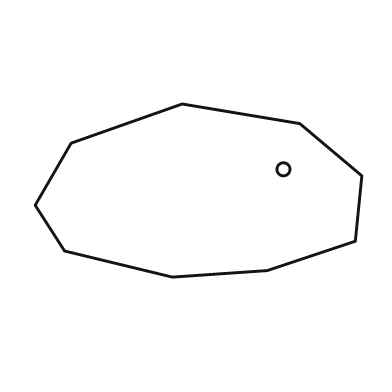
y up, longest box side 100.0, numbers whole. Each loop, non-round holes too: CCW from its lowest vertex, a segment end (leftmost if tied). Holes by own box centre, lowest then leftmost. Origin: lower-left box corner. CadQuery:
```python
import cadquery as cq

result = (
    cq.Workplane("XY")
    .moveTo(42.0, 0.0)
    .lineTo(71.0, 2.0)
    .lineTo(98.0, 11.0)
    .lineTo(100.0, 31.0)
    .lineTo(81.0, 47.0)
    .lineTo(45.0, 53.0)
    .lineTo(11.0, 41.0)
    .lineTo(0.0, 22.0)
    .lineTo(9.0, 8.0)
    .close()
    .moveTo(76.0, 33.0)
    .circle(2.0)
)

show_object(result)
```